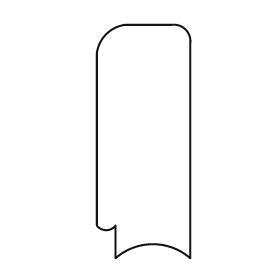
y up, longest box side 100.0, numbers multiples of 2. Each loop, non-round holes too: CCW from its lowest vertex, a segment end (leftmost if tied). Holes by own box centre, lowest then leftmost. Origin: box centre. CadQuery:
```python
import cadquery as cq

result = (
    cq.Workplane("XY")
    .moveTo(-12.0, -50.0)
    .threePointArc((4.0, -44.0), (20.0, -50.0))
    .lineTo(20.0, 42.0)
    .threePointArc((18.0, 48.0), (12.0, 50.0))
    .lineTo(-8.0, 50.0)
    .threePointArc((-16.0, 46.0), (-20.0, 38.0))
    .lineTo(-20.0, -36.0)
    .threePointArc((-16.0, -38.0), (-12.0, -36.0))
    .close()
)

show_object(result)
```